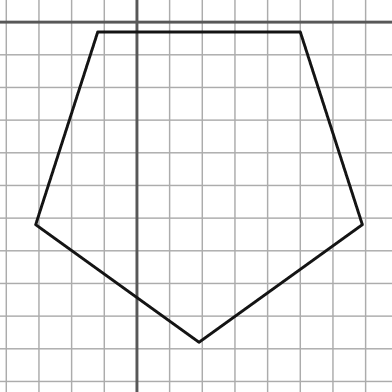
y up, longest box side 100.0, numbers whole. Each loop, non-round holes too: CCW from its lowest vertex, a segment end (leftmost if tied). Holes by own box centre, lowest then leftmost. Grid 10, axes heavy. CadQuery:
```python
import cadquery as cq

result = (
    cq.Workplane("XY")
    .moveTo(19.0, -98.0)
    .lineTo(69.0, -62.0)
    .lineTo(50.0, -3.0)
    .lineTo(-12.0, -3.0)
    .lineTo(-31.0, -62.0)
    .close()
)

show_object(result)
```